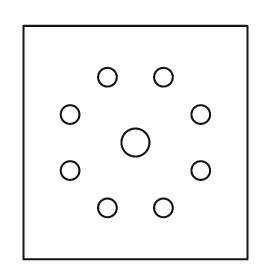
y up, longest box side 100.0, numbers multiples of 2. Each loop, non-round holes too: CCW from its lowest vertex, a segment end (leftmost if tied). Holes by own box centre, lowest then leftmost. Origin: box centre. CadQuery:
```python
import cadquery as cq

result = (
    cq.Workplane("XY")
    .moveTo(-48.0, -50.0)
    .lineTo(48.0, -50.0)
    .lineTo(48.0, 50.0)
    .lineTo(-48.0, 50.0)
    .close()
    .moveTo(-12.0, -28.0)
    .circle(4.0)
    .moveTo(12.0, -28.0)
    .circle(4.0)
    .moveTo(-28.0, -12.0)
    .circle(4.0)
    .moveTo(28.0, -12.0)
    .circle(4.0)
    .moveTo(0.0, 0.0)
    .circle(6.0)
    .moveTo(-28.0, 12.0)
    .circle(4.0)
    .moveTo(28.0, 12.0)
    .circle(4.0)
    .moveTo(-12.0, 28.0)
    .circle(4.0)
    .moveTo(12.0, 28.0)
    .circle(4.0)
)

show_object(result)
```